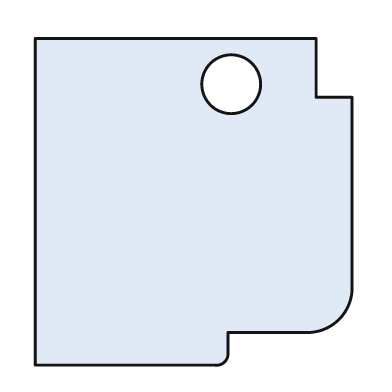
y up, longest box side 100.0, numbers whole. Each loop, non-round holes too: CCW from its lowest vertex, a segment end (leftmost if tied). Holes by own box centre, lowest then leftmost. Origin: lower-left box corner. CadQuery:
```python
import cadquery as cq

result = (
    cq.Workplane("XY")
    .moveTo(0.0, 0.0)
    .lineTo(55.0, 0.0)
    .threePointArc((58.0, 1.0), (59.0, 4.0))
    .lineTo(59.0, 10.0)
    .lineTo(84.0, 10.0)
    .threePointArc((93.0, 14.0), (97.0, 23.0))
    .lineTo(97.0, 82.0)
    .lineTo(86.0, 82.0)
    .lineTo(86.0, 100.0)
    .lineTo(0.0, 100.0)
    .close()
    .moveTo(60.0, 86.0)
    .circle(9.0)
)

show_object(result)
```